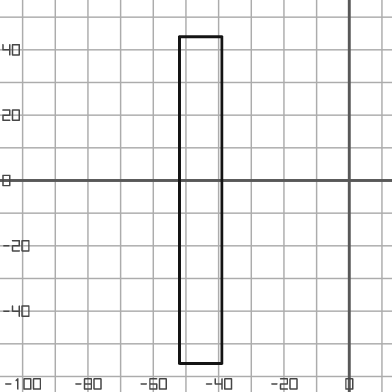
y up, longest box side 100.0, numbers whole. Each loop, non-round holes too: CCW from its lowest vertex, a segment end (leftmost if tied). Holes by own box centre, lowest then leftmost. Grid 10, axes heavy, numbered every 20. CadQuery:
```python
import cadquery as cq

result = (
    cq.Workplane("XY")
    .moveTo(-52.0, -56.0)
    .lineTo(-39.0, -56.0)
    .lineTo(-39.0, 44.0)
    .lineTo(-52.0, 44.0)
    .close()
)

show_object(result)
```